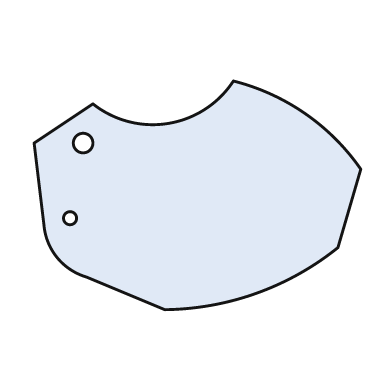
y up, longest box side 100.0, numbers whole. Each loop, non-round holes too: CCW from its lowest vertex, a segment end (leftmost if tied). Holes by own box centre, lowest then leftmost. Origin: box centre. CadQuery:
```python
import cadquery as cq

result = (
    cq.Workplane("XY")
    .moveTo(-10.0, -35.0)
    .threePointArc((18.0, -30.0), (43.0, -16.0))
    .lineTo(50.0, 8.0)
    .threePointArc((33.0, 25.0), (11.0, 35.0))
    .threePointArc((-9.0, 22.0), (-32.0, 28.0))
    .lineTo(-50.0, 16.0)
    .lineTo(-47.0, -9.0)
    .threePointArc((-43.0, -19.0), (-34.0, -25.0))
    .close()
    .moveTo(-39.0, -7.0)
    .circle(2.0)
    .moveTo(-35.0, 16.0)
    .circle(3.0)
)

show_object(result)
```